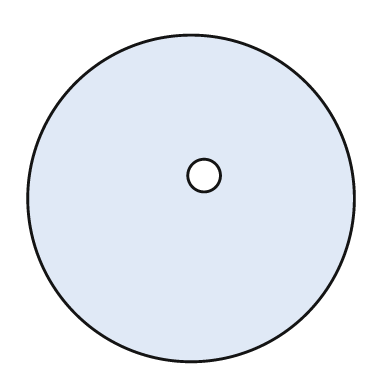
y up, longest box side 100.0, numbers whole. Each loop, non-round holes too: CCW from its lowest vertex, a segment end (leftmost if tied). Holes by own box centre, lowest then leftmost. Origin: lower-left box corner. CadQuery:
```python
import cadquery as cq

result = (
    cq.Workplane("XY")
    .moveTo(50.0, 50.0)
    .circle(50.0)
    .moveTo(54.0, 57.0)
    .circle(5.0)
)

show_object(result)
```